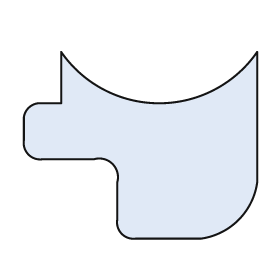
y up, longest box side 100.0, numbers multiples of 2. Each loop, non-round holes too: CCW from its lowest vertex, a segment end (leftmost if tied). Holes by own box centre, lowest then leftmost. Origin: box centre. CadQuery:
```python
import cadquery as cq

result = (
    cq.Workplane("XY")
    .moveTo(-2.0, -40.0)
    .lineTo(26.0, -40.0)
    .threePointArc((42.0, -32.0), (50.0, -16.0))
    .lineTo(50.0, 40.0)
    .threePointArc((8.0, 18.0), (-34.0, 40.0))
    .lineTo(-34.0, 18.0)
    .lineTo(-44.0, 18.0)
    .threePointArc((-48.0, 16.0), (-50.0, 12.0))
    .lineTo(-50.0, 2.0)
    .threePointArc((-48.0, -4.0), (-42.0, -6.0))
    .lineTo(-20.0, -6.0)
    .threePointArc((-12.0, -8.0), (-10.0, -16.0))
    .lineTo(-10.0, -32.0)
    .threePointArc((-8.0, -38.0), (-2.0, -40.0))
    .close()
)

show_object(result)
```